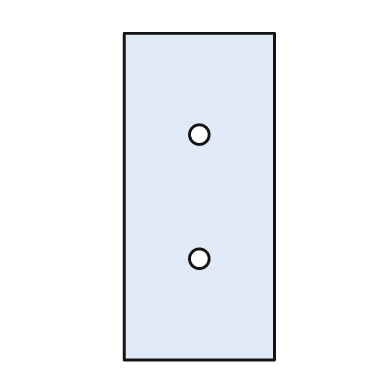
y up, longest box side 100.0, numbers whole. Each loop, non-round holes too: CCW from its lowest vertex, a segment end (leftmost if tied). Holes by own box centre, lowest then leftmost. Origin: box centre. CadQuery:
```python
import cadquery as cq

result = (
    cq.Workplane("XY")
    .moveTo(-23.0, -50.0)
    .lineTo(23.0, -50.0)
    .lineTo(23.0, 50.0)
    .lineTo(-23.0, 50.0)
    .close()
    .moveTo(0.0, -19.0)
    .circle(3.0)
    .moveTo(0.0, 19.0)
    .circle(3.0)
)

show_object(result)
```